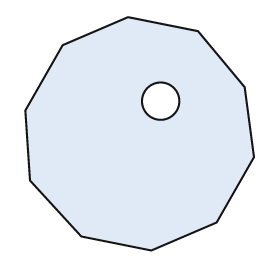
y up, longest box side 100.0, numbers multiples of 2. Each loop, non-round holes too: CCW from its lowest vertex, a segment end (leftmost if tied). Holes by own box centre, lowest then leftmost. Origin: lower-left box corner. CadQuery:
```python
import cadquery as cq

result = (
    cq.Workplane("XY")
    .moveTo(54.0, 0.0)
    .lineTo(82.0, 12.0)
    .lineTo(98.0, 40.0)
    .lineTo(94.0, 70.0)
    .lineTo(74.0, 94.0)
    .lineTo(44.0, 100.0)
    .lineTo(16.0, 88.0)
    .lineTo(0.0, 60.0)
    .lineTo(2.0, 30.0)
    .lineTo(24.0, 6.0)
    .close()
    .moveTo(58.0, 64.0)
    .circle(8.0)
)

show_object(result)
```